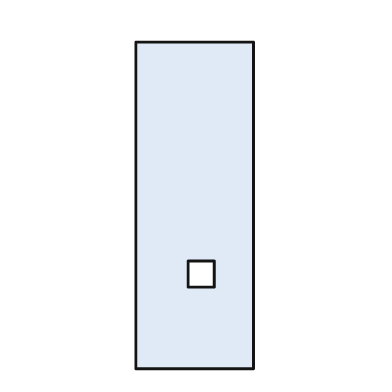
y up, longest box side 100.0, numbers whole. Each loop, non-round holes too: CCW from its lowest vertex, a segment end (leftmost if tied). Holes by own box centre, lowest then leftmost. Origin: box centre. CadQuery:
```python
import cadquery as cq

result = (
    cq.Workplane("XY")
    .moveTo(-18.0, -50.0)
    .lineTo(18.0, -50.0)
    .lineTo(18.0, 50.0)
    .lineTo(-18.0, 50.0)
    .close()
    .moveTo(-2.0, -25.0)
    .lineTo(6.0, -25.0)
    .lineTo(6.0, -17.0)
    .lineTo(-2.0, -17.0)
    .close()
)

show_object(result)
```